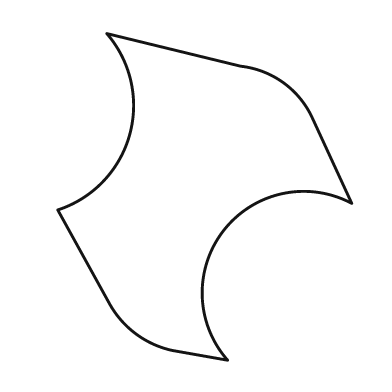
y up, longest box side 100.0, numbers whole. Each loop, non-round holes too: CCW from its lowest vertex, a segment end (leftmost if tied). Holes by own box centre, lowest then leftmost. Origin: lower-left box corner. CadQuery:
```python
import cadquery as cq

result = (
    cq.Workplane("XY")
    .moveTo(52.0, 0.0)
    .threePointArc((51.0, 40.0), (90.0, 48.0))
    .lineTo(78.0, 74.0)
    .threePointArc((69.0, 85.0), (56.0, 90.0))
    .lineTo(15.0, 100.0)
    .threePointArc((22.0, 69.0), (0.0, 46.0))
    .lineTo(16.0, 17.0)
    .threePointArc((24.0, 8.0), (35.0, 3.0))
    .close()
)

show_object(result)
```